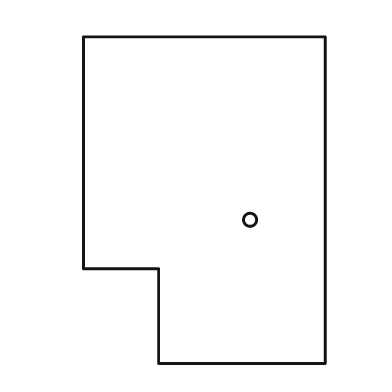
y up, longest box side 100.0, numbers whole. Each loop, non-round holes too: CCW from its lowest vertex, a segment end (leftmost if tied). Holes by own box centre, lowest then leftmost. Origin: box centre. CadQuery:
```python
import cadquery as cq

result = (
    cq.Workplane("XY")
    .moveTo(-14.0, -50.0)
    .lineTo(37.0, -50.0)
    .lineTo(37.0, 50.0)
    .lineTo(-37.0, 50.0)
    .lineTo(-37.0, -21.0)
    .lineTo(-14.0, -21.0)
    .close()
    .moveTo(14.0, -6.0)
    .circle(2.0)
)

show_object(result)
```